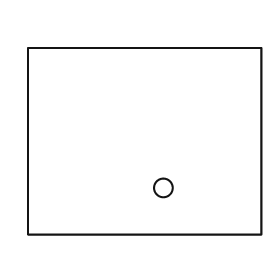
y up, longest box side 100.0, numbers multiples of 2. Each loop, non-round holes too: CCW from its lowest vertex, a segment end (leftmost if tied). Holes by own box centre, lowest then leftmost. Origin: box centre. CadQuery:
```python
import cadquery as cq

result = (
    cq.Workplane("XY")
    .moveTo(-50.0, -40.0)
    .lineTo(50.0, -40.0)
    .lineTo(50.0, 40.0)
    .lineTo(-50.0, 40.0)
    .close()
    .moveTo(8.0, -20.0)
    .circle(4.0)
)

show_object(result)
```